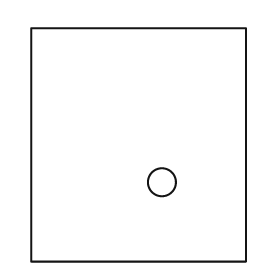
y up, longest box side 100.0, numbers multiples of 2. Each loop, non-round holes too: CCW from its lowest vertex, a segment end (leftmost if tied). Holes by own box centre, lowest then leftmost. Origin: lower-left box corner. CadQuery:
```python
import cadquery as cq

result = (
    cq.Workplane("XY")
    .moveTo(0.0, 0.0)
    .lineTo(92.0, 0.0)
    .lineTo(92.0, 100.0)
    .lineTo(0.0, 100.0)
    .close()
    .moveTo(56.0, 34.0)
    .circle(6.0)
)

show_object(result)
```